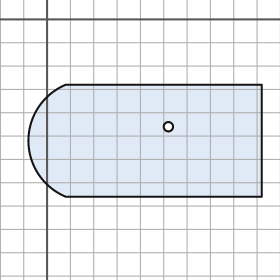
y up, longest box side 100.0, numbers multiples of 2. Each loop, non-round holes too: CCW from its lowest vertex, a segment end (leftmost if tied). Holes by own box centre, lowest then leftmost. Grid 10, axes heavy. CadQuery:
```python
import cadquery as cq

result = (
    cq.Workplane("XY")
    .moveTo(8.0, -76.0)
    .lineTo(92.0, -76.0)
    .lineTo(92.0, -28.0)
    .lineTo(8.0, -28.0)
    .threePointArc((-8.0, -52.0), (8.0, -76.0))
    .close()
    .moveTo(52.0, -46.0)
    .circle(2.0)
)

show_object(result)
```